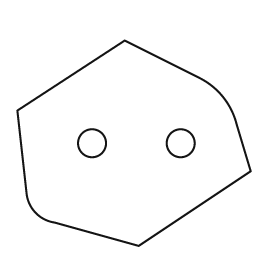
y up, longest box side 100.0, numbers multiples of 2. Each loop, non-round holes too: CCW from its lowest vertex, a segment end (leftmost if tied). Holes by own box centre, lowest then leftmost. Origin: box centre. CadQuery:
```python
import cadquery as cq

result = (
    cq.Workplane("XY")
    .moveTo(2.0, -44.0)
    .lineTo(50.0, -12.0)
    .lineTo(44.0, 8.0)
    .threePointArc((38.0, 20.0), (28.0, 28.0))
    .lineTo(-4.0, 44.0)
    .lineTo(-50.0, 14.0)
    .lineTo(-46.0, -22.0)
    .threePointArc((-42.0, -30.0), (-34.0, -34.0))
    .close()
    .moveTo(-18.0, 0.0)
    .circle(6.0)
    .moveTo(20.0, 0.0)
    .circle(6.0)
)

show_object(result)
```